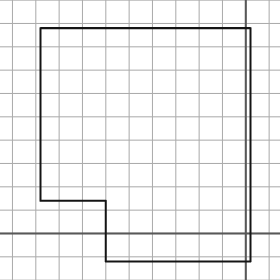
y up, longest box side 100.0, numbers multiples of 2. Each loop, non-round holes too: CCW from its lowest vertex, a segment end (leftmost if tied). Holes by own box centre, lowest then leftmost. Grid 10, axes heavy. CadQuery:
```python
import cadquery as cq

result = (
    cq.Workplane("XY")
    .moveTo(-60.0, -12.0)
    .lineTo(2.0, -12.0)
    .lineTo(2.0, 88.0)
    .lineTo(-88.0, 88.0)
    .lineTo(-88.0, 14.0)
    .lineTo(-60.0, 14.0)
    .close()
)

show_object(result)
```